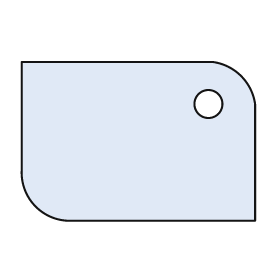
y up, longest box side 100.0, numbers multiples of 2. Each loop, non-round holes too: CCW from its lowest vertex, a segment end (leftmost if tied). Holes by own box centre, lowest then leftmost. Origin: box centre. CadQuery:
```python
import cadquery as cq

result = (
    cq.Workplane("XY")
    .moveTo(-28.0, -34.0)
    .lineTo(50.0, -34.0)
    .lineTo(50.0, 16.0)
    .threePointArc((44.0, 28.0), (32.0, 34.0))
    .lineTo(-50.0, 34.0)
    .lineTo(-50.0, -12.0)
    .threePointArc((-44.0, -28.0), (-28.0, -34.0))
    .close()
    .moveTo(30.0, 16.0)
    .circle(6.0)
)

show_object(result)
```